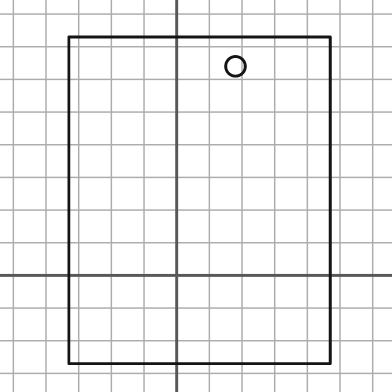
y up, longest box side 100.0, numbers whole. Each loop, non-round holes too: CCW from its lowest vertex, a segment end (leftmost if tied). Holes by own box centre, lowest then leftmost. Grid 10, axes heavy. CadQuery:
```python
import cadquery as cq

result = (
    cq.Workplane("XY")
    .moveTo(-33.0, -27.0)
    .lineTo(47.0, -27.0)
    .lineTo(47.0, 73.0)
    .lineTo(-33.0, 73.0)
    .close()
    .moveTo(18.0, 64.0)
    .circle(3.0)
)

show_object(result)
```